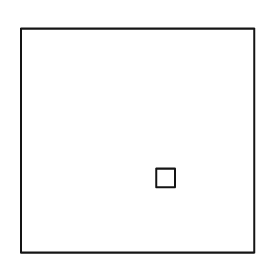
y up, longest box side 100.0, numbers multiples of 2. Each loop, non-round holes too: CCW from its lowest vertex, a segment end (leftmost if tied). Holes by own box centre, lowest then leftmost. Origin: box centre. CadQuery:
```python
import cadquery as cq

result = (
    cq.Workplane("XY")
    .moveTo(-50.0, -48.0)
    .lineTo(50.0, -48.0)
    .lineTo(50.0, 48.0)
    .lineTo(-50.0, 48.0)
    .close()
    .moveTo(8.0, -20.0)
    .lineTo(16.0, -20.0)
    .lineTo(16.0, -12.0)
    .lineTo(8.0, -12.0)
    .close()
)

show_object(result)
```